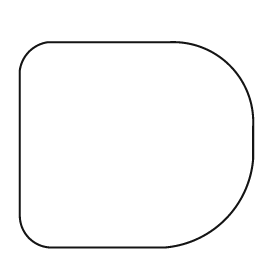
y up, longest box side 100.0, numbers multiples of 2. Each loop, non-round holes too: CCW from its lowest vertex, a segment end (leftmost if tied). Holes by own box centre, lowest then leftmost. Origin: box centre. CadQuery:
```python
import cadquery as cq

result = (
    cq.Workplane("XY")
    .moveTo(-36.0, -44.0)
    .lineTo(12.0, -44.0)
    .threePointArc((38.0, -32.0), (50.0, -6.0))
    .lineTo(50.0, 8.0)
    .threePointArc((40.0, 34.0), (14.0, 44.0))
    .lineTo(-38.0, 44.0)
    .threePointArc((-46.0, 40.0), (-50.0, 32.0))
    .lineTo(-50.0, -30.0)
    .threePointArc((-46.0, -40.0), (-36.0, -44.0))
    .close()
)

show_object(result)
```